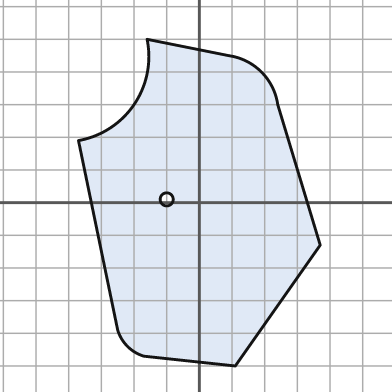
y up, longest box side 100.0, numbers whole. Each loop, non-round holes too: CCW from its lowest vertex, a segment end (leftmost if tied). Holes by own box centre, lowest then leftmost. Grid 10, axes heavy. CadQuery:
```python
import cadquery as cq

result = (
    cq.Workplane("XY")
    .moveTo(11.0, -50.0)
    .lineTo(37.0, -13.0)
    .lineTo(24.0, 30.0)
    .threePointArc((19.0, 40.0), (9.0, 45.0))
    .lineTo(-16.0, 50.0)
    .threePointArc((-20.0, 30.0), (-37.0, 19.0))
    .lineTo(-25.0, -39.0)
    .threePointArc((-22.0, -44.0), (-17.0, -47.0))
    .close()
    .moveTo(-10.0, 1.0)
    .circle(2.0)
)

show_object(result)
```